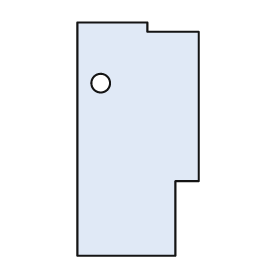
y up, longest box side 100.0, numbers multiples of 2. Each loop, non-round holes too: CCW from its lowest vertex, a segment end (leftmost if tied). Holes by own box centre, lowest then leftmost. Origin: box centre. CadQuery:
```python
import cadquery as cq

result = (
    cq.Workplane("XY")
    .moveTo(-26.0, -50.0)
    .lineTo(16.0, -50.0)
    .lineTo(16.0, -18.0)
    .lineTo(26.0, -18.0)
    .lineTo(26.0, 46.0)
    .lineTo(4.0, 46.0)
    .lineTo(4.0, 50.0)
    .lineTo(-26.0, 50.0)
    .close()
    .moveTo(-16.0, 24.0)
    .circle(4.0)
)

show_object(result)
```